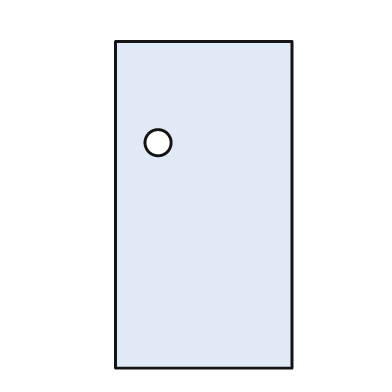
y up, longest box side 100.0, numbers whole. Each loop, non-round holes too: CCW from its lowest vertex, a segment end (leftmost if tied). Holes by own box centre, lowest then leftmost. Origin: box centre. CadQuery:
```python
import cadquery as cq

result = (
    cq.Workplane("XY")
    .moveTo(-27.0, -50.0)
    .lineTo(27.0, -50.0)
    .lineTo(27.0, 50.0)
    .lineTo(-27.0, 50.0)
    .close()
    .moveTo(-14.0, 19.0)
    .circle(4.0)
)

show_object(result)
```